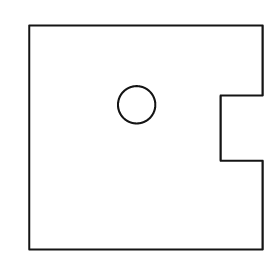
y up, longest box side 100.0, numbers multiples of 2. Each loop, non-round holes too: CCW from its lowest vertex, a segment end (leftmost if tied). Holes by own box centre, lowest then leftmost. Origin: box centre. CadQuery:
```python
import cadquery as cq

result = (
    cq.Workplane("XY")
    .moveTo(-50.0, -48.0)
    .lineTo(50.0, -48.0)
    .lineTo(50.0, -10.0)
    .lineTo(32.0, -10.0)
    .lineTo(32.0, 18.0)
    .lineTo(50.0, 18.0)
    .lineTo(50.0, 48.0)
    .lineTo(-50.0, 48.0)
    .close()
    .moveTo(-4.0, 14.0)
    .circle(8.0)
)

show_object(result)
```